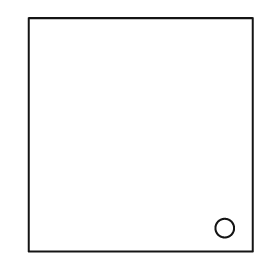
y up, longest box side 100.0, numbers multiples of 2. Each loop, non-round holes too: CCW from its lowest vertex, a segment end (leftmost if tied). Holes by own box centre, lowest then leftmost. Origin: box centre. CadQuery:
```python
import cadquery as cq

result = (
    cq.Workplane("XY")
    .moveTo(-48.0, -50.0)
    .lineTo(48.0, -50.0)
    .lineTo(48.0, 50.0)
    .lineTo(-48.0, 50.0)
    .close()
    .moveTo(36.0, -40.0)
    .circle(4.0)
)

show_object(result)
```